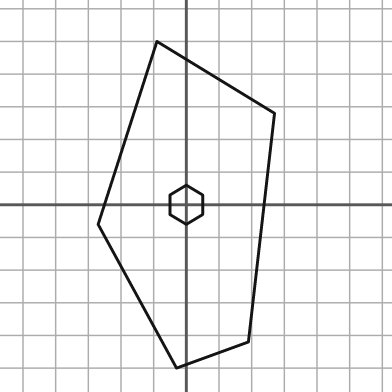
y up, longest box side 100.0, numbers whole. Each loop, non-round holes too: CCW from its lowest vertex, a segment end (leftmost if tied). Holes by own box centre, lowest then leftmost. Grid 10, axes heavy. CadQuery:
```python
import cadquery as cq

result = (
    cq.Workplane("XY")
    .moveTo(-3.0, -50.0)
    .lineTo(19.0, -42.0)
    .lineTo(27.0, 28.0)
    .lineTo(-9.0, 50.0)
    .lineTo(-27.0, -6.0)
    .close()
    .moveTo(0.0, -6.0)
    .lineTo(5.0, -3.0)
    .lineTo(5.0, 3.0)
    .lineTo(0.0, 6.0)
    .lineTo(-5.0, 3.0)
    .lineTo(-5.0, -3.0)
    .close()
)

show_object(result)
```